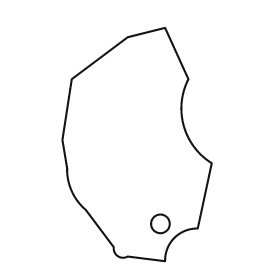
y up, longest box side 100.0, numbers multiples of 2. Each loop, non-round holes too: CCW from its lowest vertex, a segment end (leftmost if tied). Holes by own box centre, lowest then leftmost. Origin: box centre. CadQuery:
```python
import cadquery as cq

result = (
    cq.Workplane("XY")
    .moveTo(12.0, -50.0)
    .threePointArc((16.0, -40.0), (26.0, -36.0))
    .lineTo(32.0, -8.0)
    .threePointArc((20.0, 8.0), (22.0, 28.0))
    .lineTo(12.0, 50.0)
    .lineTo(-4.0, 46.0)
    .lineTo(-28.0, 28.0)
    .lineTo(-32.0, 2.0)
    .lineTo(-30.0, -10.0)
    .threePointArc((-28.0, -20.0), (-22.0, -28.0))
    .lineTo(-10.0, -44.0)
    .threePointArc((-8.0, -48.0), (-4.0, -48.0))
    .close()
    .moveTo(10.0, -34.0)
    .circle(4.0)
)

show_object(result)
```